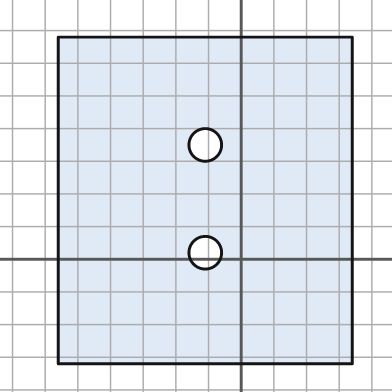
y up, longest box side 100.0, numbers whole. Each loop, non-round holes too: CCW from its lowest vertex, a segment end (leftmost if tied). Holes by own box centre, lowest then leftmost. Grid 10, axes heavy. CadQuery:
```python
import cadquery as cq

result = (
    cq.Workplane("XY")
    .moveTo(-56.0, -32.0)
    .lineTo(34.0, -32.0)
    .lineTo(34.0, 68.0)
    .lineTo(-56.0, 68.0)
    .close()
    .moveTo(-11.0, 2.0)
    .circle(5.0)
    .moveTo(-11.0, 35.0)
    .circle(5.0)
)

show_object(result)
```